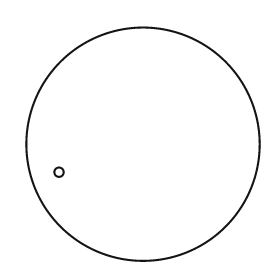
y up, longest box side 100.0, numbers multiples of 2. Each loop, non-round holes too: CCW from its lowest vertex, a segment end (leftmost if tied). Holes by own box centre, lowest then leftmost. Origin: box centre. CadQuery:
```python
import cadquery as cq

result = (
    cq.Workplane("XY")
    .moveTo(0.0, 0.0)
    .circle(50.0)
    .moveTo(-36.0, -12.0)
    .circle(2.0)
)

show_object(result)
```